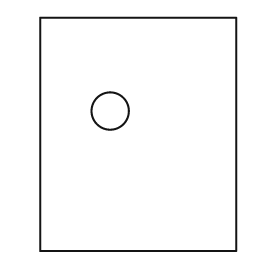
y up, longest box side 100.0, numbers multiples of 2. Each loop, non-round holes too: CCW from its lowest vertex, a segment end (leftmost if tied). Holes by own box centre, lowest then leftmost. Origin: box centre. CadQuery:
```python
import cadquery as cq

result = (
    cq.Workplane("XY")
    .moveTo(-42.0, -50.0)
    .lineTo(42.0, -50.0)
    .lineTo(42.0, 50.0)
    .lineTo(-42.0, 50.0)
    .close()
    .moveTo(-12.0, 10.0)
    .circle(8.0)
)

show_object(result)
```